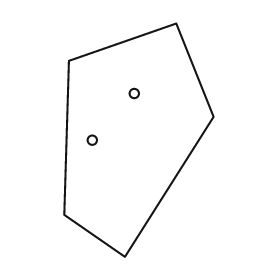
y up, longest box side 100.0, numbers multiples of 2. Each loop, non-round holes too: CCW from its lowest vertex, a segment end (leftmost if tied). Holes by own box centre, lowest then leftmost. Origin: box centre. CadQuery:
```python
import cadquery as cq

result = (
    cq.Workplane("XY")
    .moveTo(-6.0, -50.0)
    .lineTo(32.0, 10.0)
    .lineTo(16.0, 50.0)
    .lineTo(-30.0, 34.0)
    .lineTo(-32.0, -32.0)
    .close()
    .moveTo(-20.0, 0.0)
    .circle(2.0)
    .moveTo(-2.0, 20.0)
    .circle(2.0)
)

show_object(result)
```